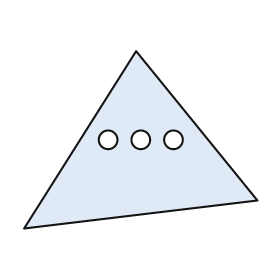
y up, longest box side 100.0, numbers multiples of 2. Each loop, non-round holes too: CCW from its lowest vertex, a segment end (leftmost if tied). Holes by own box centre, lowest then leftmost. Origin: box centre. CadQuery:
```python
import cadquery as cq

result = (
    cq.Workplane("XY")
    .moveTo(-50.0, -38.0)
    .lineTo(50.0, -26.0)
    .lineTo(-2.0, 38.0)
    .close()
    .moveTo(-14.0, 0.0)
    .circle(4.0)
    .moveTo(0.0, 0.0)
    .circle(4.0)
    .moveTo(14.0, 0.0)
    .circle(4.0)
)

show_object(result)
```